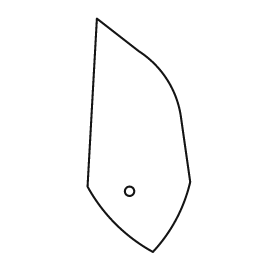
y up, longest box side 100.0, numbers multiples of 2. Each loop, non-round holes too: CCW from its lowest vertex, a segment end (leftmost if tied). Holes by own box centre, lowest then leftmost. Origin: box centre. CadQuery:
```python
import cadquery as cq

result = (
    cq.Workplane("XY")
    .moveTo(6.0, -50.0)
    .threePointArc((16.0, -36.0), (22.0, -20.0))
    .lineTo(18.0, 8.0)
    .threePointArc((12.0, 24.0), (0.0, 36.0))
    .lineTo(-18.0, 50.0)
    .lineTo(-22.0, -22.0)
    .threePointArc((-10.0, -38.0), (6.0, -50.0))
    .close()
    .moveTo(-4.0, -24.0)
    .circle(2.0)
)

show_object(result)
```